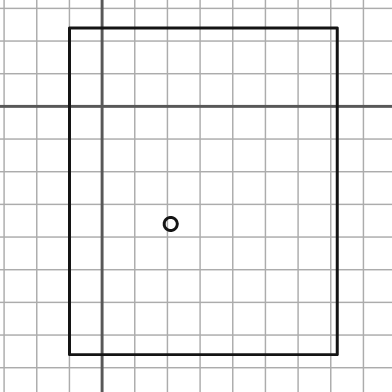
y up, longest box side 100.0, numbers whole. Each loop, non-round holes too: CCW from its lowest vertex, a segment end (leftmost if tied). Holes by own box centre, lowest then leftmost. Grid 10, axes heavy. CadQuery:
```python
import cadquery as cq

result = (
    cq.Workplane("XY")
    .moveTo(-10.0, -76.0)
    .lineTo(72.0, -76.0)
    .lineTo(72.0, 24.0)
    .lineTo(-10.0, 24.0)
    .close()
    .moveTo(21.0, -36.0)
    .circle(2.0)
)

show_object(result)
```